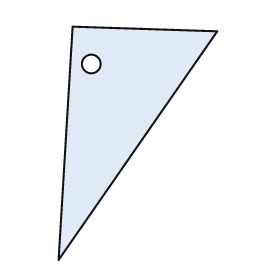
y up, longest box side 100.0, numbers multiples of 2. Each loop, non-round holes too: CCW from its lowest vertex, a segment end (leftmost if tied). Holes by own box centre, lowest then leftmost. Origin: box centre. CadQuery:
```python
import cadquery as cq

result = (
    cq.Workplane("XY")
    .moveTo(-34.0, -50.0)
    .lineTo(34.0, 48.0)
    .lineTo(-28.0, 50.0)
    .close()
    .moveTo(-20.0, 34.0)
    .circle(4.0)
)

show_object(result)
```